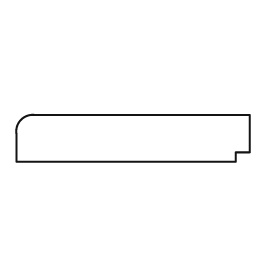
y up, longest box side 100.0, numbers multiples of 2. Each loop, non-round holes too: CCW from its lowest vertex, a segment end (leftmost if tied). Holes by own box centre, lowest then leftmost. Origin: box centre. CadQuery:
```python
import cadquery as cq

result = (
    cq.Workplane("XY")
    .moveTo(-50.0, -10.0)
    .lineTo(44.0, -10.0)
    .lineTo(44.0, -6.0)
    .lineTo(50.0, -6.0)
    .lineTo(50.0, 10.0)
    .lineTo(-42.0, 10.0)
    .threePointArc((-48.0, 8.0), (-50.0, 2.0))
    .close()
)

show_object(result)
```